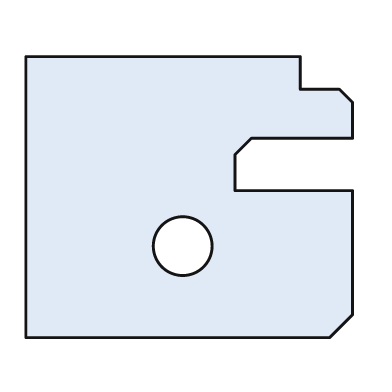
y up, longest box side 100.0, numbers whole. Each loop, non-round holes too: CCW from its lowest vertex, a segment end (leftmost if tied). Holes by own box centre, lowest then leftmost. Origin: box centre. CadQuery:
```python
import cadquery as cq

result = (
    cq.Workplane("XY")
    .moveTo(-50.0, -43.0)
    .lineTo(43.0, -43.0)
    .lineTo(50.0, -36.0)
    .lineTo(50.0, 2.0)
    .lineTo(14.0, 2.0)
    .lineTo(14.0, 13.0)
    .lineTo(19.0, 18.0)
    .lineTo(50.0, 18.0)
    .lineTo(50.0, 29.0)
    .lineTo(46.0, 33.0)
    .lineTo(34.0, 33.0)
    .lineTo(34.0, 43.0)
    .lineTo(-50.0, 43.0)
    .close()
    .moveTo(-2.0, -15.0)
    .circle(9.0)
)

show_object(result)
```